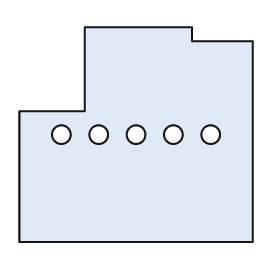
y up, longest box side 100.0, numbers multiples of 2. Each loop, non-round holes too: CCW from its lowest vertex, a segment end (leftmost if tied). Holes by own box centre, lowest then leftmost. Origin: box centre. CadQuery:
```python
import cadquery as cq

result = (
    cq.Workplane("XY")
    .moveTo(-50.0, -46.0)
    .lineTo(50.0, -46.0)
    .lineTo(50.0, 40.0)
    .lineTo(24.0, 40.0)
    .lineTo(24.0, 46.0)
    .lineTo(-22.0, 46.0)
    .lineTo(-22.0, 10.0)
    .lineTo(-50.0, 10.0)
    .close()
    .moveTo(-32.0, 0.0)
    .circle(4.0)
    .moveTo(-16.0, 0.0)
    .circle(4.0)
    .moveTo(0.0, 0.0)
    .circle(4.0)
    .moveTo(16.0, 0.0)
    .circle(4.0)
    .moveTo(32.0, 0.0)
    .circle(4.0)
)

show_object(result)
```